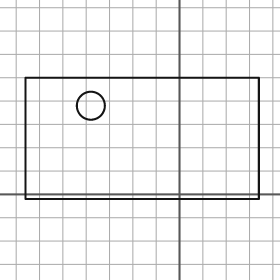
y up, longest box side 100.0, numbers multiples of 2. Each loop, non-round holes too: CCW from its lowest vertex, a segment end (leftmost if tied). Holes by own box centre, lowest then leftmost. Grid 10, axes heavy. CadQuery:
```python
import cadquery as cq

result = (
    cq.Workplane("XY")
    .moveTo(-66.0, -2.0)
    .lineTo(34.0, -2.0)
    .lineTo(34.0, 50.0)
    .lineTo(-66.0, 50.0)
    .close()
    .moveTo(-38.0, 38.0)
    .circle(6.0)
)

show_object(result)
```